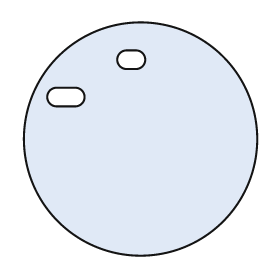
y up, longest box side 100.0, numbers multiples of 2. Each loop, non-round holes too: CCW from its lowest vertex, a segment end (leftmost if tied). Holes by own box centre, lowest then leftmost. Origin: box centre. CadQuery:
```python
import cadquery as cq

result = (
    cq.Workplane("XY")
    .moveTo(0.0, 0.0)
    .circle(50.0)
    .moveTo(-36.0, 14.0)
    .lineTo(-28.0, 14.0)
    .threePointArc((-24.0, 18.0), (-28.0, 22.0))
    .lineTo(-36.0, 22.0)
    .threePointArc((-40.0, 18.0), (-36.0, 14.0))
    .close()
    .moveTo(-6.0, 30.0)
    .lineTo(-2.0, 30.0)
    .threePointArc((2.0, 34.0), (-2.0, 38.0))
    .lineTo(-6.0, 38.0)
    .threePointArc((-10.0, 34.0), (-6.0, 30.0))
    .close()
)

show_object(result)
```